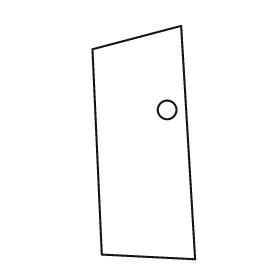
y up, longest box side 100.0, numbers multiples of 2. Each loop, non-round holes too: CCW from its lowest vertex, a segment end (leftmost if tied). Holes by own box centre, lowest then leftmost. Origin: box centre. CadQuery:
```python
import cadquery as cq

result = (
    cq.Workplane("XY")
    .moveTo(22.0, -50.0)
    .lineTo(16.0, 50.0)
    .lineTo(-22.0, 40.0)
    .lineTo(-18.0, -48.0)
    .close()
    .moveTo(10.0, 14.0)
    .circle(4.0)
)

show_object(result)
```